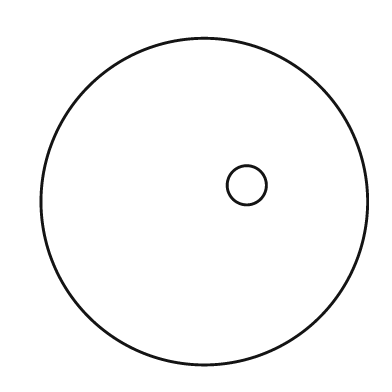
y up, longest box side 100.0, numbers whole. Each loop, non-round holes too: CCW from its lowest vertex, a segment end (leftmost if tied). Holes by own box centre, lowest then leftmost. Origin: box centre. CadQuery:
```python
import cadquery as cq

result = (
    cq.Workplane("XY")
    .moveTo(0.0, 0.0)
    .circle(50.0)
    .moveTo(13.0, 5.0)
    .circle(6.0)
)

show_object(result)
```